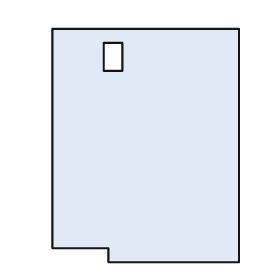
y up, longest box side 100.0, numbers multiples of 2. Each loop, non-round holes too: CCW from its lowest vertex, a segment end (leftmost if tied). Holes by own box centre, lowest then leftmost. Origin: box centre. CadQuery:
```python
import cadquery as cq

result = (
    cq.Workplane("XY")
    .moveTo(-16.0, -50.0)
    .lineTo(40.0, -50.0)
    .lineTo(40.0, 50.0)
    .lineTo(-40.0, 50.0)
    .lineTo(-40.0, -44.0)
    .lineTo(-16.0, -44.0)
    .close()
    .moveTo(-18.0, 32.0)
    .lineTo(-10.0, 32.0)
    .lineTo(-10.0, 44.0)
    .lineTo(-18.0, 44.0)
    .close()
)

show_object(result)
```